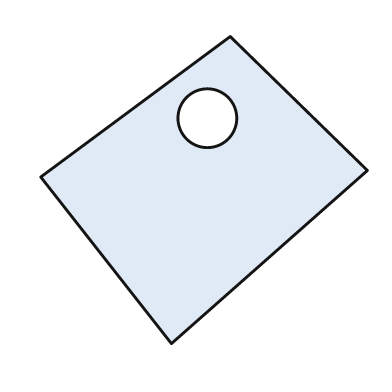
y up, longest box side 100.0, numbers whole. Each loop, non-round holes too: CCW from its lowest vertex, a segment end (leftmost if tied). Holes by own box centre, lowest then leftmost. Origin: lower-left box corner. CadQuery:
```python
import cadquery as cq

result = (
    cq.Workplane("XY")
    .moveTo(40.0, 0.0)
    .lineTo(100.0, 53.0)
    .lineTo(58.0, 94.0)
    .lineTo(0.0, 51.0)
    .close()
    .moveTo(51.0, 69.0)
    .circle(9.0)
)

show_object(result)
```